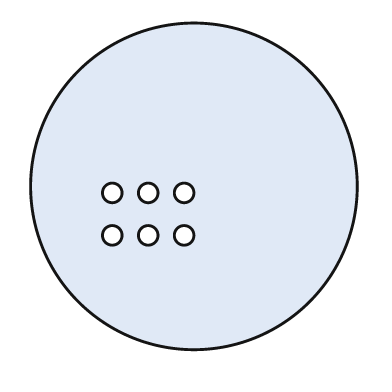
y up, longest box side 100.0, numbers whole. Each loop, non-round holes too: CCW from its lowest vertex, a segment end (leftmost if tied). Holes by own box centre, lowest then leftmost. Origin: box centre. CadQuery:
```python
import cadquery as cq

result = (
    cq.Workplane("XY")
    .moveTo(0.0, 0.0)
    .circle(50.0)
    .moveTo(-25.0, -15.0)
    .circle(3.0)
    .moveTo(-14.0, -15.0)
    .circle(3.0)
    .moveTo(-3.0, -15.0)
    .circle(3.0)
    .moveTo(-25.0, -2.0)
    .circle(3.0)
    .moveTo(-14.0, -2.0)
    .circle(3.0)
    .moveTo(-3.0, -2.0)
    .circle(3.0)
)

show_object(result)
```